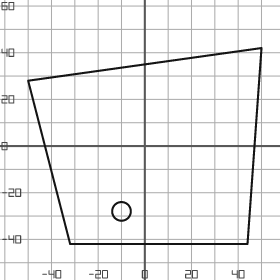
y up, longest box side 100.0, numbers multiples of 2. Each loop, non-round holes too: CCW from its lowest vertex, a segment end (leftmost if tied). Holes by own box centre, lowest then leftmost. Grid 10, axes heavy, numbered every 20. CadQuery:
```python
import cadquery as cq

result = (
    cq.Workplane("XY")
    .moveTo(-32.0, -42.0)
    .lineTo(44.0, -42.0)
    .lineTo(50.0, 42.0)
    .lineTo(-50.0, 28.0)
    .close()
    .moveTo(-10.0, -28.0)
    .circle(4.0)
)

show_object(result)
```